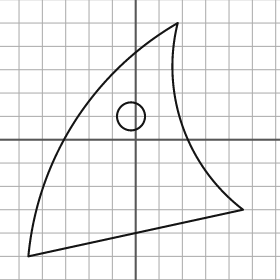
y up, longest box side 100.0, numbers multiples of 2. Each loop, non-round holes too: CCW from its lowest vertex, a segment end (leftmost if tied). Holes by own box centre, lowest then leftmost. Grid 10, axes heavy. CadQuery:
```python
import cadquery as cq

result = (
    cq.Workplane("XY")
    .moveTo(-46.0, -50.0)
    .lineTo(46.0, -30.0)
    .threePointArc((20.0, 6.0), (18.0, 50.0))
    .threePointArc((-26.0, 8.0), (-46.0, -50.0))
    .close()
    .moveTo(-2.0, 10.0)
    .circle(6.0)
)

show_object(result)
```